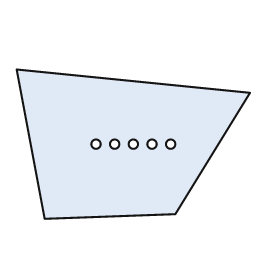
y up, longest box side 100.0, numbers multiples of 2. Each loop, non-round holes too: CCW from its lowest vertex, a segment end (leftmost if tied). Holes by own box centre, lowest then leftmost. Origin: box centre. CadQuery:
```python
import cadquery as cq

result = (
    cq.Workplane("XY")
    .moveTo(-38.0, -32.0)
    .lineTo(18.0, -30.0)
    .lineTo(50.0, 22.0)
    .lineTo(-50.0, 32.0)
    .close()
    .moveTo(-16.0, 0.0)
    .circle(2.0)
    .moveTo(-8.0, 0.0)
    .circle(2.0)
    .moveTo(0.0, 0.0)
    .circle(2.0)
    .moveTo(8.0, 0.0)
    .circle(2.0)
    .moveTo(16.0, 0.0)
    .circle(2.0)
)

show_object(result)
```